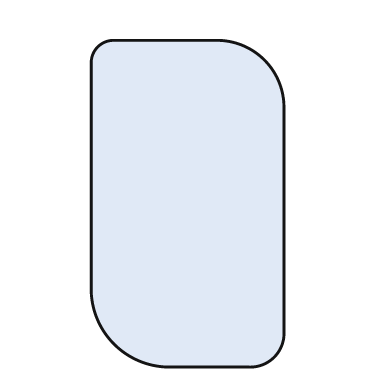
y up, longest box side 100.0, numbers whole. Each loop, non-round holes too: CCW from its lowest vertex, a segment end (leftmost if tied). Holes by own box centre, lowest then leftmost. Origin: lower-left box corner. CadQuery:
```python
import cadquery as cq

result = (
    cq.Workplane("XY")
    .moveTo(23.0, 0.0)
    .lineTo(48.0, 0.0)
    .threePointArc((56.0, 3.0), (59.0, 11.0))
    .lineTo(59.0, 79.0)
    .threePointArc((53.0, 94.0), (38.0, 100.0))
    .lineTo(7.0, 100.0)
    .threePointArc((2.0, 98.0), (0.0, 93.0))
    .lineTo(0.0, 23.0)
    .threePointArc((7.0, 7.0), (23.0, 0.0))
    .close()
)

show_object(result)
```